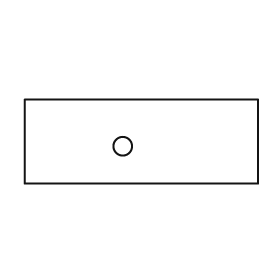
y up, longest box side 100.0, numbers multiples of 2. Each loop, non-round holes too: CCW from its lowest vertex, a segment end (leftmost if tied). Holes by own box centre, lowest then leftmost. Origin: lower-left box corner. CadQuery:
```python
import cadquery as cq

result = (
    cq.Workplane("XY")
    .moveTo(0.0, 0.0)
    .lineTo(100.0, 0.0)
    .lineTo(100.0, 36.0)
    .lineTo(0.0, 36.0)
    .close()
    .moveTo(42.0, 16.0)
    .circle(4.0)
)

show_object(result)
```